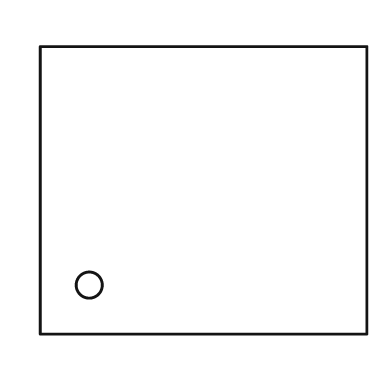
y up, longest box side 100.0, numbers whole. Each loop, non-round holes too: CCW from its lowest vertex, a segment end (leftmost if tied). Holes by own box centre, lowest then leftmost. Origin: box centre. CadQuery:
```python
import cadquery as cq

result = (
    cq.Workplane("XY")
    .moveTo(-50.0, -44.0)
    .lineTo(50.0, -44.0)
    .lineTo(50.0, 44.0)
    .lineTo(-50.0, 44.0)
    .close()
    .moveTo(-35.0, -29.0)
    .circle(4.0)
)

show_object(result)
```